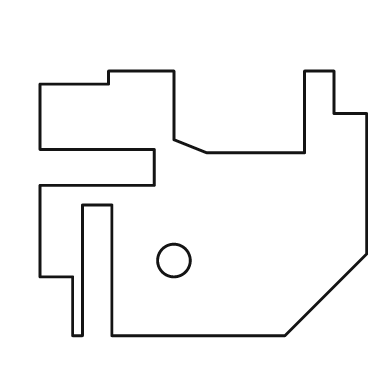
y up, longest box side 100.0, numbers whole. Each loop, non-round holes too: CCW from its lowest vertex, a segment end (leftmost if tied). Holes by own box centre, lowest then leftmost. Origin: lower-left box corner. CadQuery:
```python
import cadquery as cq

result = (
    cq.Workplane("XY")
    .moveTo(10.0, 0.0)
    .lineTo(13.0, 0.0)
    .lineTo(13.0, 40.0)
    .lineTo(22.0, 40.0)
    .lineTo(22.0, 0.0)
    .lineTo(75.0, 0.0)
    .lineTo(100.0, 25.0)
    .lineTo(100.0, 68.0)
    .lineTo(90.0, 68.0)
    .lineTo(90.0, 81.0)
    .lineTo(81.0, 81.0)
    .lineTo(81.0, 56.0)
    .lineTo(51.0, 56.0)
    .lineTo(41.0, 60.0)
    .lineTo(41.0, 81.0)
    .lineTo(21.0, 81.0)
    .lineTo(21.0, 77.0)
    .lineTo(0.0, 77.0)
    .lineTo(0.0, 57.0)
    .lineTo(35.0, 57.0)
    .lineTo(35.0, 46.0)
    .lineTo(0.0, 46.0)
    .lineTo(0.0, 18.0)
    .lineTo(10.0, 18.0)
    .close()
    .moveTo(41.0, 23.0)
    .circle(5.0)
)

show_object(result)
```